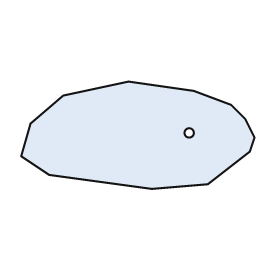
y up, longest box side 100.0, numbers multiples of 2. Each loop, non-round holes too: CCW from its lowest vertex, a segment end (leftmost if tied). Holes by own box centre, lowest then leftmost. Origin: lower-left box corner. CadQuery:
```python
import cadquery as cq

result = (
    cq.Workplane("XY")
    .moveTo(56.0, 0.0)
    .lineTo(80.0, 2.0)
    .lineTo(98.0, 16.0)
    .lineTo(100.0, 22.0)
    .lineTo(96.0, 30.0)
    .lineTo(90.0, 36.0)
    .lineTo(74.0, 42.0)
    .lineTo(46.0, 46.0)
    .lineTo(18.0, 40.0)
    .lineTo(4.0, 28.0)
    .lineTo(0.0, 14.0)
    .lineTo(12.0, 6.0)
    .close()
    .moveTo(72.0, 24.0)
    .circle(2.0)
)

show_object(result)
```